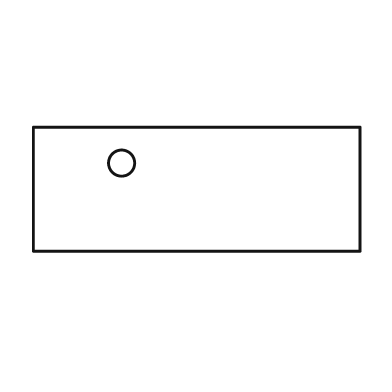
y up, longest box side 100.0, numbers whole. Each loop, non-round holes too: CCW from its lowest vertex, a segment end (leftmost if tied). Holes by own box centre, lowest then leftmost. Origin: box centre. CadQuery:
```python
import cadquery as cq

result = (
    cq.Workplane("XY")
    .moveTo(-50.0, -19.0)
    .lineTo(50.0, -19.0)
    .lineTo(50.0, 19.0)
    .lineTo(-50.0, 19.0)
    .close()
    .moveTo(-23.0, 8.0)
    .circle(4.0)
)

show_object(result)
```